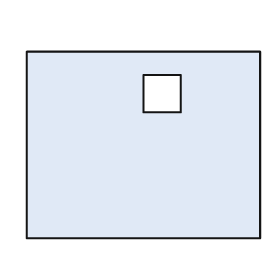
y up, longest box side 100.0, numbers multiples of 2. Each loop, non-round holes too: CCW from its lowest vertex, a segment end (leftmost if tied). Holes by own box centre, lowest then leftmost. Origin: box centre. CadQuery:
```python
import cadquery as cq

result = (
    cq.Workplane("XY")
    .moveTo(-50.0, -40.0)
    .lineTo(50.0, -40.0)
    .lineTo(50.0, 40.0)
    .lineTo(-50.0, 40.0)
    .close()
    .moveTo(0.0, 14.0)
    .lineTo(16.0, 14.0)
    .lineTo(16.0, 30.0)
    .lineTo(0.0, 30.0)
    .close()
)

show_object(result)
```